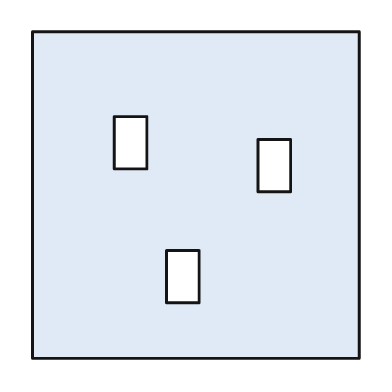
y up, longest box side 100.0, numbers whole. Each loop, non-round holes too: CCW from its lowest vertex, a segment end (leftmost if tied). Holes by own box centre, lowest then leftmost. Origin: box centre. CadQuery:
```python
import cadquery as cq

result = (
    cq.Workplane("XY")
    .moveTo(-50.0, -50.0)
    .lineTo(50.0, -50.0)
    .lineTo(50.0, 50.0)
    .lineTo(-50.0, 50.0)
    .close()
    .moveTo(-9.0, -33.0)
    .lineTo(1.0, -33.0)
    .lineTo(1.0, -17.0)
    .lineTo(-9.0, -17.0)
    .close()
    .moveTo(19.0, 1.0)
    .lineTo(29.0, 1.0)
    .lineTo(29.0, 17.0)
    .lineTo(19.0, 17.0)
    .close()
    .moveTo(-25.0, 8.0)
    .lineTo(-15.0, 8.0)
    .lineTo(-15.0, 24.0)
    .lineTo(-25.0, 24.0)
    .close()
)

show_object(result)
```